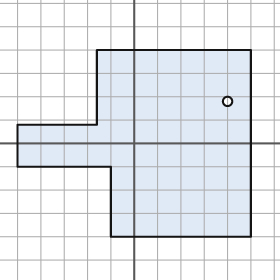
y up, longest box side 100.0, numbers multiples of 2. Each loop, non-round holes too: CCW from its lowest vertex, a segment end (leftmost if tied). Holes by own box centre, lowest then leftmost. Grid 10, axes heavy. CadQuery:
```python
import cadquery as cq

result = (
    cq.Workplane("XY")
    .moveTo(-10.0, -40.0)
    .lineTo(50.0, -40.0)
    .lineTo(50.0, 40.0)
    .lineTo(-16.0, 40.0)
    .lineTo(-16.0, 8.0)
    .lineTo(-50.0, 8.0)
    .lineTo(-50.0, -10.0)
    .lineTo(-10.0, -10.0)
    .close()
    .moveTo(40.0, 18.0)
    .circle(2.0)
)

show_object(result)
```